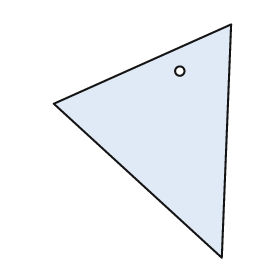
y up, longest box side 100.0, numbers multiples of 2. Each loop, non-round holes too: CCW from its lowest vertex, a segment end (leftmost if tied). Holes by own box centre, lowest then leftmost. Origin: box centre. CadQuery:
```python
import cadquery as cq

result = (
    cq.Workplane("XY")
    .moveTo(34.0, -50.0)
    .lineTo(38.0, 50.0)
    .lineTo(-38.0, 16.0)
    .close()
    .moveTo(16.0, 30.0)
    .circle(2.0)
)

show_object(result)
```